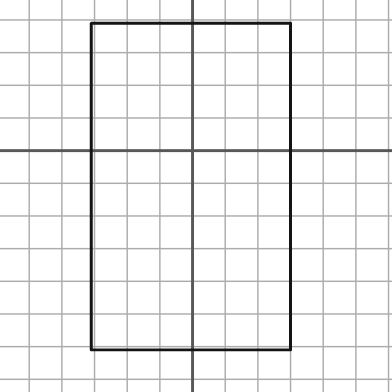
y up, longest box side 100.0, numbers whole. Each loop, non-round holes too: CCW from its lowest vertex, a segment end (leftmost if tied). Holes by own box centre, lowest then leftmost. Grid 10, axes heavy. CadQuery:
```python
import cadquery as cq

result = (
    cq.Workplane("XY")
    .moveTo(-31.0, -61.0)
    .lineTo(30.0, -61.0)
    .lineTo(30.0, 39.0)
    .lineTo(-31.0, 39.0)
    .close()
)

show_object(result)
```